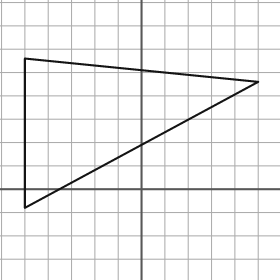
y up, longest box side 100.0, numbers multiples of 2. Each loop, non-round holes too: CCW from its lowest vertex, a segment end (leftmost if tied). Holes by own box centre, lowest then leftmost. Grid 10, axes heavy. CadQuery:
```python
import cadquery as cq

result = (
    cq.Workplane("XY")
    .moveTo(-50.0, -8.0)
    .lineTo(50.0, 46.0)
    .lineTo(-50.0, 56.0)
    .close()
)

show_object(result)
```